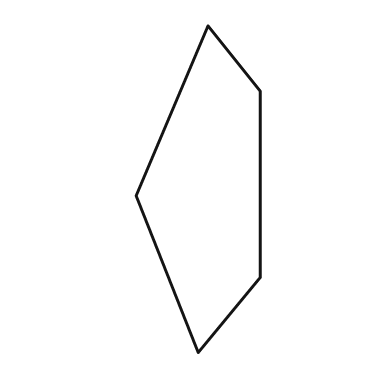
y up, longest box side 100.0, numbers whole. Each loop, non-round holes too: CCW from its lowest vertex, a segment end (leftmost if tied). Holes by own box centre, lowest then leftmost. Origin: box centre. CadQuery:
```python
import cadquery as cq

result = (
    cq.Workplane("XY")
    .moveTo(0.0, -50.0)
    .lineTo(19.0, -27.0)
    .lineTo(19.0, 30.0)
    .lineTo(3.0, 50.0)
    .lineTo(-19.0, -2.0)
    .close()
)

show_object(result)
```